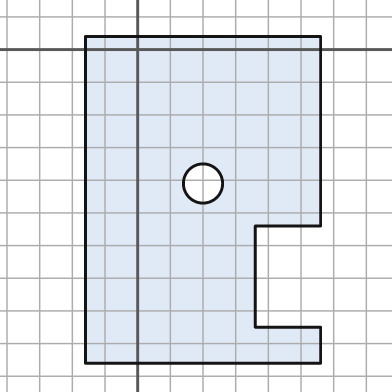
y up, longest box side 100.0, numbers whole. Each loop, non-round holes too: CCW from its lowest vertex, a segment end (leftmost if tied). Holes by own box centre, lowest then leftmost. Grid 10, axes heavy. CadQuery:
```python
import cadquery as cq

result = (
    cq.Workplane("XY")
    .moveTo(-16.0, -96.0)
    .lineTo(56.0, -96.0)
    .lineTo(56.0, -85.0)
    .lineTo(36.0, -85.0)
    .lineTo(36.0, -54.0)
    .lineTo(56.0, -54.0)
    .lineTo(56.0, 4.0)
    .lineTo(-16.0, 4.0)
    .close()
    .moveTo(20.0, -41.0)
    .circle(6.0)
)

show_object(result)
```